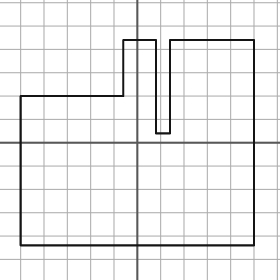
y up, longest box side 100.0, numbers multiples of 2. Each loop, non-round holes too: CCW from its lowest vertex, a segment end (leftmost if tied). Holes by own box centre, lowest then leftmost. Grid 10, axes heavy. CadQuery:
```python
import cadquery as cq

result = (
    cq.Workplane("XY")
    .moveTo(-50.0, -44.0)
    .lineTo(50.0, -44.0)
    .lineTo(50.0, 44.0)
    .lineTo(14.0, 44.0)
    .lineTo(14.0, 4.0)
    .lineTo(8.0, 4.0)
    .lineTo(8.0, 44.0)
    .lineTo(-6.0, 44.0)
    .lineTo(-6.0, 20.0)
    .lineTo(-50.0, 20.0)
    .close()
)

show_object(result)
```